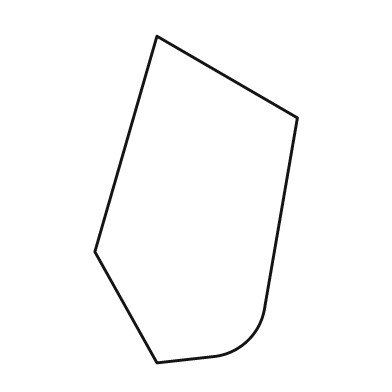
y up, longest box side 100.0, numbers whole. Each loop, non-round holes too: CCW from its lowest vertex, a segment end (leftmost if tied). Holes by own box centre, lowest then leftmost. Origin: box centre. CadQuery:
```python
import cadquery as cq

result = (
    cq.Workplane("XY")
    .moveTo(-12.0, -50.0)
    .lineTo(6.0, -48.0)
    .threePointArc((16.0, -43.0), (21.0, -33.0))
    .lineTo(31.0, 25.0)
    .lineTo(-12.0, 50.0)
    .lineTo(-31.0, -16.0)
    .close()
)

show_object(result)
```